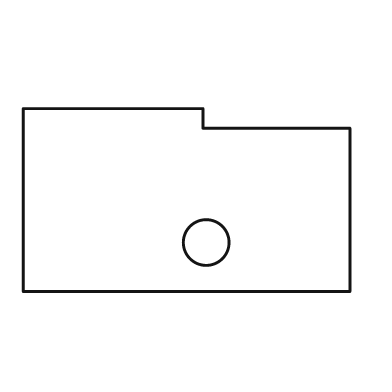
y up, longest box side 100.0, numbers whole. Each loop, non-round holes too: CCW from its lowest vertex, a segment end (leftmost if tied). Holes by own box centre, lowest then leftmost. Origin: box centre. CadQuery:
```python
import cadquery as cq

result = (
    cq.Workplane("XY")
    .moveTo(-50.0, -28.0)
    .lineTo(50.0, -28.0)
    .lineTo(50.0, 22.0)
    .lineTo(5.0, 22.0)
    .lineTo(5.0, 28.0)
    .lineTo(-50.0, 28.0)
    .close()
    .moveTo(6.0, -13.0)
    .circle(7.0)
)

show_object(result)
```